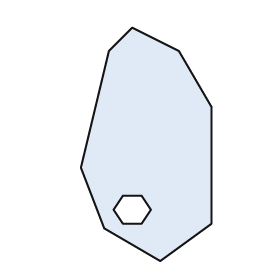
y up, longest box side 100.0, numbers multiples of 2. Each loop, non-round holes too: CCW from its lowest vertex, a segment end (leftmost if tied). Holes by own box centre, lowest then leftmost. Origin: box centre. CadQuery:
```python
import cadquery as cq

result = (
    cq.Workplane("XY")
    .moveTo(6.0, -50.0)
    .lineTo(28.0, -34.0)
    .lineTo(28.0, 16.0)
    .lineTo(14.0, 40.0)
    .lineTo(-6.0, 50.0)
    .lineTo(-16.0, 40.0)
    .lineTo(-28.0, -10.0)
    .lineTo(-18.0, -36.0)
    .close()
    .moveTo(-10.0, -34.0)
    .lineTo(-2.0, -34.0)
    .lineTo(2.0, -28.0)
    .lineTo(-2.0, -22.0)
    .lineTo(-10.0, -22.0)
    .lineTo(-14.0, -28.0)
    .close()
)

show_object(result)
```